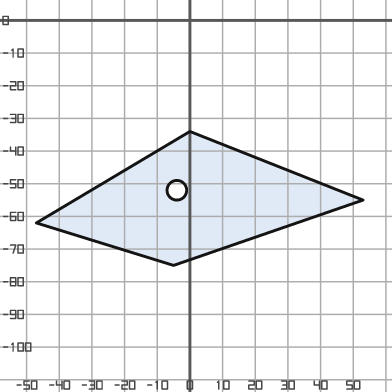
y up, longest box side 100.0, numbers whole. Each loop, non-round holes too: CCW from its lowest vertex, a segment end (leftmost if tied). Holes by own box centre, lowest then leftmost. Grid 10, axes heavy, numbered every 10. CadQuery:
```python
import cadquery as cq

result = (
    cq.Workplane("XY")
    .moveTo(-5.0, -75.0)
    .lineTo(53.0, -55.0)
    .lineTo(0.0, -34.0)
    .lineTo(-47.0, -62.0)
    .close()
    .moveTo(-4.0, -52.0)
    .circle(3.0)
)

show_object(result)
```